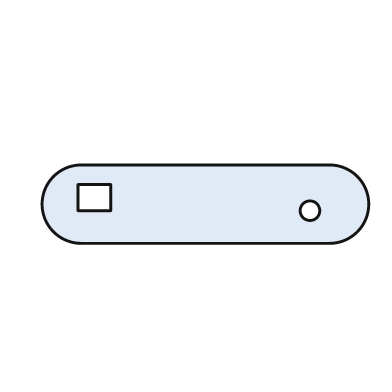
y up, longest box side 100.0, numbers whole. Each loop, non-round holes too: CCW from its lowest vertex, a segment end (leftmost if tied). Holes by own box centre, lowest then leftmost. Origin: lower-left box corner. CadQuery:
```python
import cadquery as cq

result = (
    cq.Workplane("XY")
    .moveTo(12.0, 0.0)
    .lineTo(88.0, 0.0)
    .threePointArc((100.0, 12.0), (88.0, 24.0))
    .lineTo(12.0, 24.0)
    .threePointArc((0.0, 12.0), (12.0, 0.0))
    .close()
    .moveTo(82.0, 10.0)
    .circle(3.0)
    .moveTo(11.0, 10.0)
    .lineTo(21.0, 10.0)
    .lineTo(21.0, 18.0)
    .lineTo(11.0, 18.0)
    .close()
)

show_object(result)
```